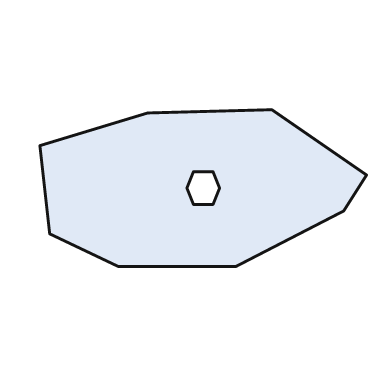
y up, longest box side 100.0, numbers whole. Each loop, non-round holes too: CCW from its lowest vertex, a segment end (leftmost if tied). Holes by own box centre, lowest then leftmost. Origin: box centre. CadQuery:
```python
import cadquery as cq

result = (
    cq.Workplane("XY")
    .moveTo(-26.0, -24.0)
    .lineTo(10.0, -24.0)
    .lineTo(43.0, -7.0)
    .lineTo(50.0, 4.0)
    .lineTo(21.0, 24.0)
    .lineTo(-17.0, 23.0)
    .lineTo(-50.0, 13.0)
    .lineTo(-47.0, -14.0)
    .close()
    .moveTo(-3.0, -5.0)
    .lineTo(3.0, -5.0)
    .lineTo(5.0, 0.0)
    .lineTo(3.0, 5.0)
    .lineTo(-3.0, 5.0)
    .lineTo(-5.0, 0.0)
    .close()
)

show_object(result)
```